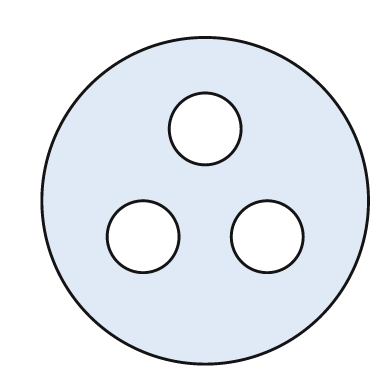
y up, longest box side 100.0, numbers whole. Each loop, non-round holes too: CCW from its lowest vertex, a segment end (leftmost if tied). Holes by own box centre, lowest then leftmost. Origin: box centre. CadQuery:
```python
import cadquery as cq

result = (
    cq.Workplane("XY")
    .moveTo(0.0, 0.0)
    .circle(50.0)
    .moveTo(-19.0, -11.0)
    .circle(11.0)
    .moveTo(19.0, -11.0)
    .circle(11.0)
    .moveTo(0.0, 22.0)
    .circle(11.0)
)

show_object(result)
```